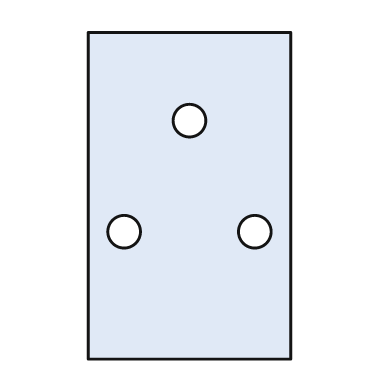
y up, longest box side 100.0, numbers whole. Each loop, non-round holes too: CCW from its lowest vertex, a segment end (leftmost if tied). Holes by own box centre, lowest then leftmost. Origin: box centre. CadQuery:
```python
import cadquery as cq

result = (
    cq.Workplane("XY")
    .moveTo(-31.0, -50.0)
    .lineTo(31.0, -50.0)
    .lineTo(31.0, 50.0)
    .lineTo(-31.0, 50.0)
    .close()
    .moveTo(-20.0, -11.0)
    .circle(5.0)
    .moveTo(20.0, -11.0)
    .circle(5.0)
    .moveTo(0.0, 23.0)
    .circle(5.0)
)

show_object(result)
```